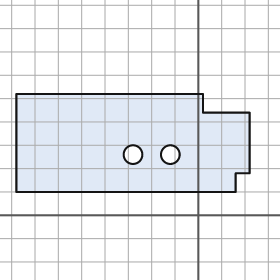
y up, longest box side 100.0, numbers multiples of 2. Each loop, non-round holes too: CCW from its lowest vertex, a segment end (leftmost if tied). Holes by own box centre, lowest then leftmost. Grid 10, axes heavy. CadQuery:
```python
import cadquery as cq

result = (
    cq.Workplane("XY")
    .moveTo(-78.0, 10.0)
    .lineTo(16.0, 10.0)
    .lineTo(16.0, 18.0)
    .lineTo(22.0, 18.0)
    .lineTo(22.0, 44.0)
    .lineTo(2.0, 44.0)
    .lineTo(2.0, 52.0)
    .lineTo(-78.0, 52.0)
    .close()
    .moveTo(-28.0, 26.0)
    .circle(4.0)
    .moveTo(-12.0, 26.0)
    .circle(4.0)
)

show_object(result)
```